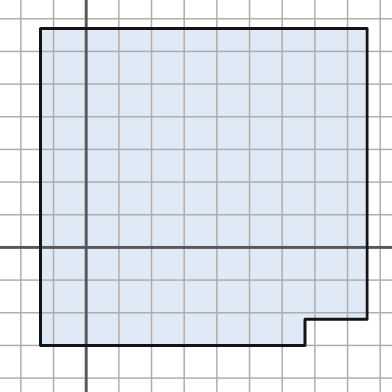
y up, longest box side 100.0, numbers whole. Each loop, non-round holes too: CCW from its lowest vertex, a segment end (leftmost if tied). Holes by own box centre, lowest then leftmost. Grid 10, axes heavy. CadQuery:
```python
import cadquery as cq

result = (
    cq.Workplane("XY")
    .moveTo(-14.0, -30.0)
    .lineTo(67.0, -30.0)
    .lineTo(67.0, -22.0)
    .lineTo(86.0, -22.0)
    .lineTo(86.0, 67.0)
    .lineTo(-14.0, 67.0)
    .close()
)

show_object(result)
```